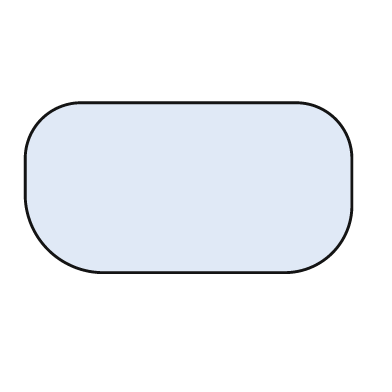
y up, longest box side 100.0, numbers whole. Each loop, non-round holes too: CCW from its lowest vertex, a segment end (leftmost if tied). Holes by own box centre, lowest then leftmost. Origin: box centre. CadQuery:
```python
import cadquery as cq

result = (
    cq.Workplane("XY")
    .moveTo(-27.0, -26.0)
    .lineTo(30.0, -26.0)
    .threePointArc((44.0, -20.0), (50.0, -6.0))
    .lineTo(50.0, 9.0)
    .threePointArc((45.0, 21.0), (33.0, 26.0))
    .lineTo(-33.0, 26.0)
    .threePointArc((-45.0, 21.0), (-50.0, 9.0))
    .lineTo(-50.0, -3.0)
    .threePointArc((-43.0, -19.0), (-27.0, -26.0))
    .close()
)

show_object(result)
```